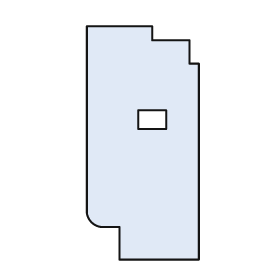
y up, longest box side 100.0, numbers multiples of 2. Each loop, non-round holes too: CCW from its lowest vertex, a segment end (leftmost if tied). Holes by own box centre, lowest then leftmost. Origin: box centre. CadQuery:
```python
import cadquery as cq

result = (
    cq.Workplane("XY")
    .moveTo(-10.0, -50.0)
    .lineTo(24.0, -50.0)
    .lineTo(24.0, 34.0)
    .lineTo(20.0, 34.0)
    .lineTo(20.0, 44.0)
    .lineTo(4.0, 44.0)
    .lineTo(4.0, 50.0)
    .lineTo(-24.0, 50.0)
    .lineTo(-24.0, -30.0)
    .threePointArc((-22.0, -34.0), (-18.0, -36.0))
    .lineTo(-10.0, -36.0)
    .close()
    .moveTo(-2.0, 6.0)
    .lineTo(10.0, 6.0)
    .lineTo(10.0, 14.0)
    .lineTo(-2.0, 14.0)
    .close()
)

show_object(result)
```